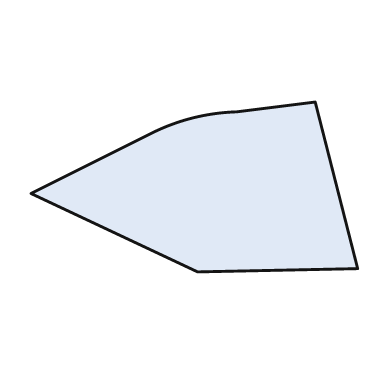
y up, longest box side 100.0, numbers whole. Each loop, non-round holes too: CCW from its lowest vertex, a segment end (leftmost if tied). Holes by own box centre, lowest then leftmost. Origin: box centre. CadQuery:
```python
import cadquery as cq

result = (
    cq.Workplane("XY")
    .moveTo(1.0, -26.0)
    .lineTo(50.0, -25.0)
    .lineTo(37.0, 26.0)
    .lineTo(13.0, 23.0)
    .threePointArc((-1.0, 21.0), (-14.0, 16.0))
    .lineTo(-50.0, -2.0)
    .close()
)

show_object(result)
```